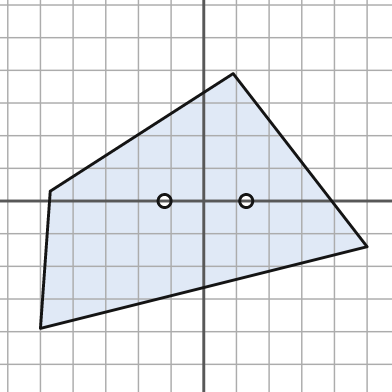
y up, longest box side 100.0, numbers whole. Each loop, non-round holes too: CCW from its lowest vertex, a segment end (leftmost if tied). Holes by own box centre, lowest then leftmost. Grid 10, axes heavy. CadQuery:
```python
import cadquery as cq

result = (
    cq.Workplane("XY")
    .moveTo(-50.0, -39.0)
    .lineTo(50.0, -14.0)
    .lineTo(9.0, 39.0)
    .lineTo(-47.0, 3.0)
    .close()
    .moveTo(-12.0, 0.0)
    .circle(2.0)
    .moveTo(13.0, 0.0)
    .circle(2.0)
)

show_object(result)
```